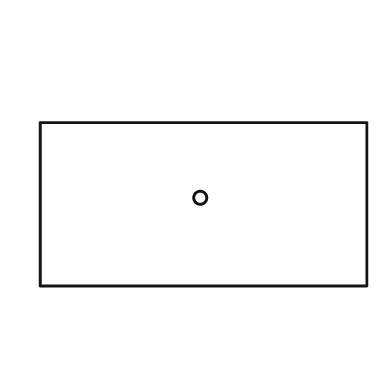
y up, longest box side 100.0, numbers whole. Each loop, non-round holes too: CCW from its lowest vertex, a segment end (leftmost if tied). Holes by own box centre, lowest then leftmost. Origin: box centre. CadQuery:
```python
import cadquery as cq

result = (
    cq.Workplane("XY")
    .moveTo(-50.0, -25.0)
    .lineTo(50.0, -25.0)
    .lineTo(50.0, 25.0)
    .lineTo(-50.0, 25.0)
    .close()
    .moveTo(-1.0, 2.0)
    .circle(2.0)
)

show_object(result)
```